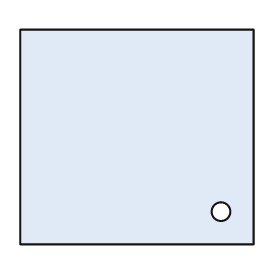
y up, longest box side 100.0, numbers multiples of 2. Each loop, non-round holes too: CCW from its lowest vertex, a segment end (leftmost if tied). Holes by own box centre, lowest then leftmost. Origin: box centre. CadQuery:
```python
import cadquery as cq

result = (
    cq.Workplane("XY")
    .moveTo(-50.0, -46.0)
    .lineTo(50.0, -46.0)
    .lineTo(50.0, 46.0)
    .lineTo(-50.0, 46.0)
    .close()
    .moveTo(36.0, -32.0)
    .circle(4.0)
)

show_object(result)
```